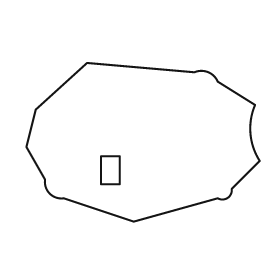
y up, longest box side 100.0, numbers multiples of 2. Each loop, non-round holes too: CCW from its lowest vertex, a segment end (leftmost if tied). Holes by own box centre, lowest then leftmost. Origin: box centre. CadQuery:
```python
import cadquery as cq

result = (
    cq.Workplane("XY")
    .moveTo(-4.0, -34.0)
    .lineTo(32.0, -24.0)
    .threePointArc((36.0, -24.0), (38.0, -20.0))
    .lineTo(50.0, -8.0)
    .threePointArc((46.0, 4.0), (48.0, 16.0))
    .lineTo(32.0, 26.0)
    .threePointArc((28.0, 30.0), (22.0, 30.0))
    .lineTo(-24.0, 34.0)
    .lineTo(-46.0, 14.0)
    .lineTo(-50.0, -2.0)
    .lineTo(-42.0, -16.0)
    .threePointArc((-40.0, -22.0), (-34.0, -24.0))
    .close()
    .moveTo(-18.0, -18.0)
    .lineTo(-10.0, -18.0)
    .lineTo(-10.0, -6.0)
    .lineTo(-18.0, -6.0)
    .close()
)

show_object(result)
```